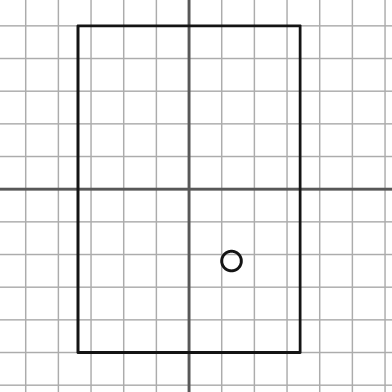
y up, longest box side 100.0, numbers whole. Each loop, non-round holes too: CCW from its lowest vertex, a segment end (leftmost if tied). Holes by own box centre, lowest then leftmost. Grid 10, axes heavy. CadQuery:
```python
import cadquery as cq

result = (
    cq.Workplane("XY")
    .moveTo(-34.0, -50.0)
    .lineTo(34.0, -50.0)
    .lineTo(34.0, 50.0)
    .lineTo(-34.0, 50.0)
    .close()
    .moveTo(13.0, -22.0)
    .circle(3.0)
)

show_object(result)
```